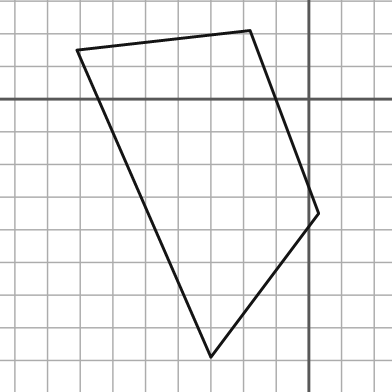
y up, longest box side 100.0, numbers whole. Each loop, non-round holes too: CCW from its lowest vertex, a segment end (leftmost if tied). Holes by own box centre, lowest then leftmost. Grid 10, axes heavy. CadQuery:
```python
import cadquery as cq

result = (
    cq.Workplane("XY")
    .moveTo(-30.0, -79.0)
    .lineTo(3.0, -35.0)
    .lineTo(-18.0, 21.0)
    .lineTo(-71.0, 15.0)
    .close()
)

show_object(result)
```